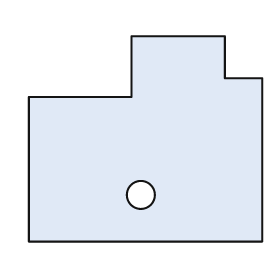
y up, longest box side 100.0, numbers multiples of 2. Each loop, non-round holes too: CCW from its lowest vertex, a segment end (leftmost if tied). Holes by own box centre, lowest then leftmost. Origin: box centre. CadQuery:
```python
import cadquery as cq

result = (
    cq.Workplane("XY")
    .moveTo(-50.0, -44.0)
    .lineTo(50.0, -44.0)
    .lineTo(50.0, 26.0)
    .lineTo(34.0, 26.0)
    .lineTo(34.0, 44.0)
    .lineTo(-6.0, 44.0)
    .lineTo(-6.0, 18.0)
    .lineTo(-50.0, 18.0)
    .close()
    .moveTo(-2.0, -24.0)
    .circle(6.0)
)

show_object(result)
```